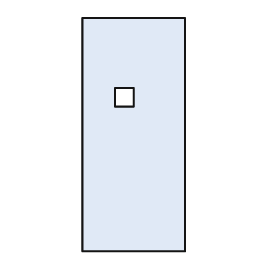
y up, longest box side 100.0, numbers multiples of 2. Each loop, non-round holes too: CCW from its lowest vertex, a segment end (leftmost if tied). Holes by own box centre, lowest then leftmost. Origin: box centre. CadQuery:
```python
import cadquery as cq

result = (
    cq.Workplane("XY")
    .moveTo(-22.0, -50.0)
    .lineTo(22.0, -50.0)
    .lineTo(22.0, 50.0)
    .lineTo(-22.0, 50.0)
    .close()
    .moveTo(-8.0, 12.0)
    .lineTo(0.0, 12.0)
    .lineTo(0.0, 20.0)
    .lineTo(-8.0, 20.0)
    .close()
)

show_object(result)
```